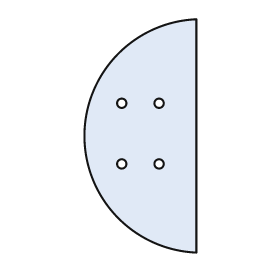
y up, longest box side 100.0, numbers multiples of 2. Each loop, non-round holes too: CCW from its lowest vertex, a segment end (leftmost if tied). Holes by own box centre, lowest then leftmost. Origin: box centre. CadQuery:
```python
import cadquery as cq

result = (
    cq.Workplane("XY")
    .moveTo(24.0, -50.0)
    .lineTo(24.0, 50.0)
    .threePointArc((-24.0, 0.0), (24.0, -50.0))
    .close()
    .moveTo(-8.0, -12.0)
    .circle(2.0)
    .moveTo(8.0, -12.0)
    .circle(2.0)
    .moveTo(-8.0, 14.0)
    .circle(2.0)
    .moveTo(8.0, 14.0)
    .circle(2.0)
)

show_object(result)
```